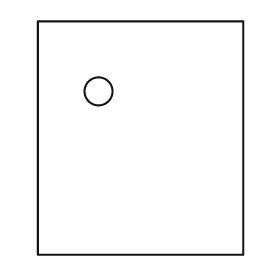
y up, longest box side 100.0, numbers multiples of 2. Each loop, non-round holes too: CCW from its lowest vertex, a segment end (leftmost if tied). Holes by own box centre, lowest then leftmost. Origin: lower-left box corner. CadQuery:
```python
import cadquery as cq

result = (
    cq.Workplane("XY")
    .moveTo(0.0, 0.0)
    .lineTo(88.0, 0.0)
    .lineTo(88.0, 100.0)
    .lineTo(0.0, 100.0)
    .close()
    .moveTo(26.0, 70.0)
    .circle(6.0)
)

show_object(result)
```